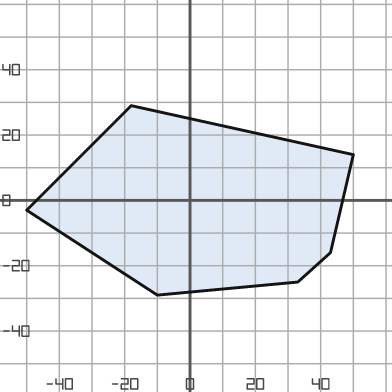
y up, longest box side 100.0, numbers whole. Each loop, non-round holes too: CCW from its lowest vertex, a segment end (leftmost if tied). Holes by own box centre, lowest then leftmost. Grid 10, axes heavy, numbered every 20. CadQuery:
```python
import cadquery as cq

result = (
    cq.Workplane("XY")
    .moveTo(-10.0, -29.0)
    .lineTo(33.0, -25.0)
    .lineTo(43.0, -16.0)
    .lineTo(50.0, 14.0)
    .lineTo(-18.0, 29.0)
    .lineTo(-50.0, -3.0)
    .close()
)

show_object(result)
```